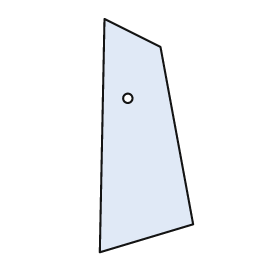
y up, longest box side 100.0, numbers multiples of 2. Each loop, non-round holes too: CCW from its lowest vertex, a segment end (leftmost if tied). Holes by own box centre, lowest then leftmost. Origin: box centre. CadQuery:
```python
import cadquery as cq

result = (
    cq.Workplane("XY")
    .moveTo(-20.0, -50.0)
    .lineTo(20.0, -38.0)
    .lineTo(6.0, 38.0)
    .lineTo(-18.0, 50.0)
    .close()
    .moveTo(-8.0, 16.0)
    .circle(2.0)
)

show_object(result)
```